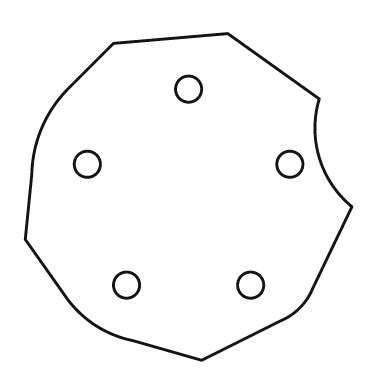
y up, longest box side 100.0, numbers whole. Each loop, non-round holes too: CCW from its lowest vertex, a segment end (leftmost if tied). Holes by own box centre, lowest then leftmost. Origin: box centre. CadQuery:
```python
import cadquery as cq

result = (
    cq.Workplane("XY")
    .moveTo(4.0, -50.0)
    .lineTo(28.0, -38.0)
    .threePointArc((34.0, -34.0), (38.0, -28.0))
    .lineTo(50.0, -3.0)
    .threePointArc((40.0, 12.0), (40.0, 30.0))
    .lineTo(12.0, 50.0)
    .lineTo(-23.0, 47.0)
    .lineTo(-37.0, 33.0)
    .threePointArc((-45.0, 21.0), (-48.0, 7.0))
    .lineTo(-50.0, -13.0)
    .lineTo(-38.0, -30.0)
    .threePointArc((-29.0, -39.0), (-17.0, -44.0))
    .close()
    .moveTo(-19.0, -27.0)
    .circle(4.0)
    .moveTo(19.0, -27.0)
    .circle(4.0)
    .moveTo(-31.0, 10.0)
    .circle(4.0)
    .moveTo(31.0, 10.0)
    .circle(4.0)
    .moveTo(0.0, 33.0)
    .circle(4.0)
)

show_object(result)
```